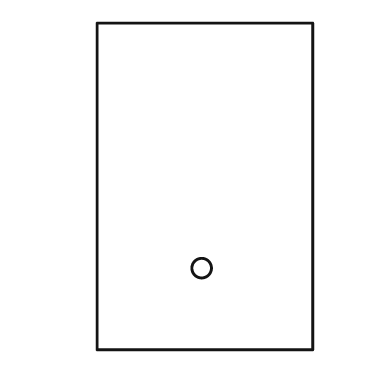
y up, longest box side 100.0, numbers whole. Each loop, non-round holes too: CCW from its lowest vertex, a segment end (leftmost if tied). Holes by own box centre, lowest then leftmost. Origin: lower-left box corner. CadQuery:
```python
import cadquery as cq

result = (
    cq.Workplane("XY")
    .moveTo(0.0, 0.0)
    .lineTo(66.0, 0.0)
    .lineTo(66.0, 100.0)
    .lineTo(0.0, 100.0)
    .close()
    .moveTo(32.0, 25.0)
    .circle(3.0)
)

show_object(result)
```